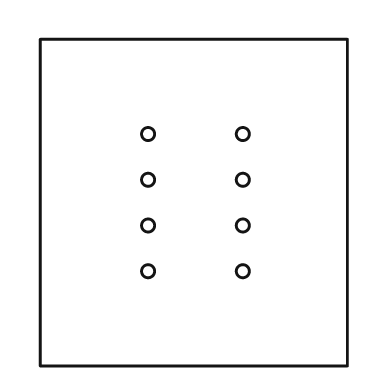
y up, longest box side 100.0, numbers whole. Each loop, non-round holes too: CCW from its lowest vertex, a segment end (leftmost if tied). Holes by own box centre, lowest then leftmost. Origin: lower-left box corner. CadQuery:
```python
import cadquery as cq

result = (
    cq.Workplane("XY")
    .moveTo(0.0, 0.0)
    .lineTo(94.0, 0.0)
    .lineTo(94.0, 100.0)
    .lineTo(0.0, 100.0)
    .close()
    .moveTo(33.0, 29.0)
    .circle(2.0)
    .moveTo(62.0, 29.0)
    .circle(2.0)
    .moveTo(33.0, 43.0)
    .circle(2.0)
    .moveTo(62.0, 43.0)
    .circle(2.0)
    .moveTo(33.0, 57.0)
    .circle(2.0)
    .moveTo(62.0, 57.0)
    .circle(2.0)
    .moveTo(33.0, 71.0)
    .circle(2.0)
    .moveTo(62.0, 71.0)
    .circle(2.0)
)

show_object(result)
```